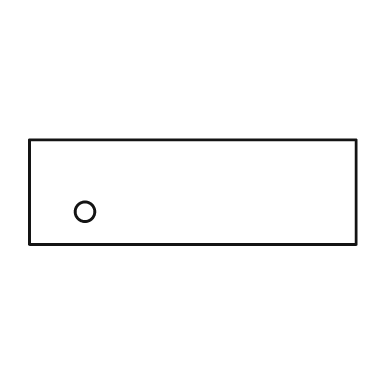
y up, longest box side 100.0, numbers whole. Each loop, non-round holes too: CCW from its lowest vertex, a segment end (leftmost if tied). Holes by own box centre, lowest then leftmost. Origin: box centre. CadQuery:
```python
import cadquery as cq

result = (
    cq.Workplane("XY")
    .moveTo(-50.0, -16.0)
    .lineTo(50.0, -16.0)
    .lineTo(50.0, 16.0)
    .lineTo(-50.0, 16.0)
    .close()
    .moveTo(-33.0, -6.0)
    .circle(3.0)
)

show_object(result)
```